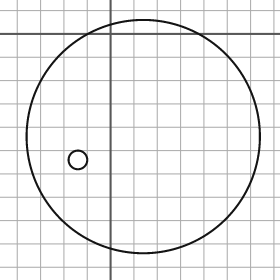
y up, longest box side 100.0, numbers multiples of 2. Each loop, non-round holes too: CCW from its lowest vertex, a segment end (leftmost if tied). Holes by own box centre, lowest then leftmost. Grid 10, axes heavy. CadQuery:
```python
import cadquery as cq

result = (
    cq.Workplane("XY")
    .moveTo(14.0, -44.0)
    .circle(50.0)
    .moveTo(-14.0, -54.0)
    .circle(4.0)
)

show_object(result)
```